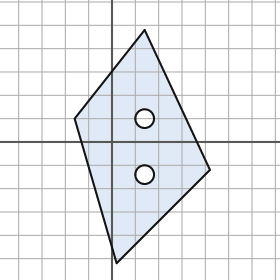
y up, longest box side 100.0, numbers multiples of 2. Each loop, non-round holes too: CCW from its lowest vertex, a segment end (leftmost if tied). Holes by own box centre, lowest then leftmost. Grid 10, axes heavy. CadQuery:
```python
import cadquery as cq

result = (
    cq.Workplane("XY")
    .moveTo(2.0, -52.0)
    .lineTo(42.0, -12.0)
    .lineTo(14.0, 48.0)
    .lineTo(-16.0, 10.0)
    .close()
    .moveTo(14.0, -14.0)
    .circle(4.0)
    .moveTo(14.0, 10.0)
    .circle(4.0)
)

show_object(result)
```